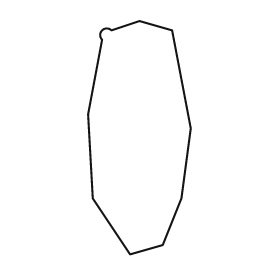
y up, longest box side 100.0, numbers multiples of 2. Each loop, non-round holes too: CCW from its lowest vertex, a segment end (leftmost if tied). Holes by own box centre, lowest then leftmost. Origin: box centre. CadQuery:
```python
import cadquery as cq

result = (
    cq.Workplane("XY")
    .moveTo(-4.0, -50.0)
    .lineTo(10.0, -46.0)
    .lineTo(18.0, -26.0)
    .lineTo(22.0, 4.0)
    .lineTo(14.0, 46.0)
    .lineTo(0.0, 50.0)
    .lineTo(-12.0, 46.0)
    .threePointArc((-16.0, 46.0), (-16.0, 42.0))
    .lineTo(-22.0, 10.0)
    .lineTo(-20.0, -26.0)
    .close()
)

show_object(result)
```